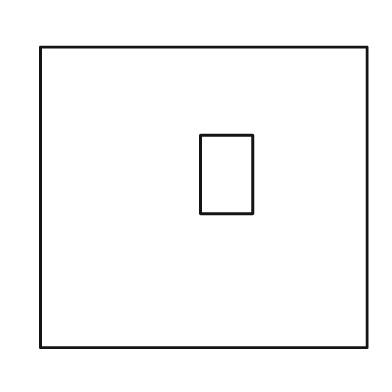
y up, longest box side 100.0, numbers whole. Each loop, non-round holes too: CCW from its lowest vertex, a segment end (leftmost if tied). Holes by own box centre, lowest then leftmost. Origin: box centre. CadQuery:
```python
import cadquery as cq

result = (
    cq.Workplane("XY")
    .moveTo(-50.0, -46.0)
    .lineTo(50.0, -46.0)
    .lineTo(50.0, 46.0)
    .lineTo(-50.0, 46.0)
    .close()
    .moveTo(-1.0, -5.0)
    .lineTo(15.0, -5.0)
    .lineTo(15.0, 19.0)
    .lineTo(-1.0, 19.0)
    .close()
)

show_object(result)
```